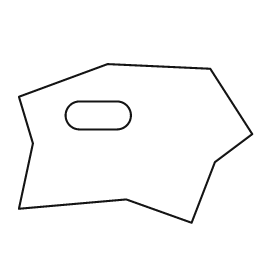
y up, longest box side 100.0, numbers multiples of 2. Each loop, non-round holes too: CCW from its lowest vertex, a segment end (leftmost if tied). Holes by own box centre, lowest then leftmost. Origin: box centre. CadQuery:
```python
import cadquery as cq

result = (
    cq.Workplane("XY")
    .moveTo(24.0, -34.0)
    .lineTo(34.0, -8.0)
    .lineTo(50.0, 4.0)
    .lineTo(32.0, 32.0)
    .lineTo(-12.0, 34.0)
    .lineTo(-50.0, 20.0)
    .lineTo(-44.0, 0.0)
    .lineTo(-50.0, -28.0)
    .lineTo(-4.0, -24.0)
    .close()
    .moveTo(-24.0, 6.0)
    .lineTo(-8.0, 6.0)
    .threePointArc((-2.0, 12.0), (-8.0, 18.0))
    .lineTo(-24.0, 18.0)
    .threePointArc((-30.0, 12.0), (-24.0, 6.0))
    .close()
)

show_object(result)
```